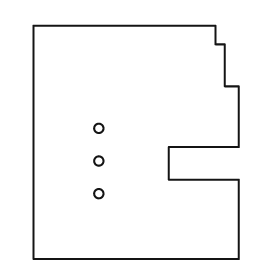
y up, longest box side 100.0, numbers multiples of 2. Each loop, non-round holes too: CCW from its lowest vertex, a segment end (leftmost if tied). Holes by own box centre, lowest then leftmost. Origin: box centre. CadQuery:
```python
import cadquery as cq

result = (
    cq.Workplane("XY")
    .moveTo(-44.0, -50.0)
    .lineTo(44.0, -50.0)
    .lineTo(44.0, -16.0)
    .lineTo(14.0, -16.0)
    .lineTo(14.0, -2.0)
    .lineTo(44.0, -2.0)
    .lineTo(44.0, 24.0)
    .lineTo(38.0, 24.0)
    .lineTo(38.0, 42.0)
    .lineTo(34.0, 42.0)
    .lineTo(34.0, 50.0)
    .lineTo(-44.0, 50.0)
    .close()
    .moveTo(-16.0, -22.0)
    .circle(2.0)
    .moveTo(-16.0, -8.0)
    .circle(2.0)
    .moveTo(-16.0, 6.0)
    .circle(2.0)
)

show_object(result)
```